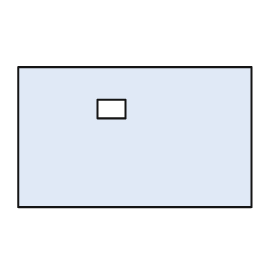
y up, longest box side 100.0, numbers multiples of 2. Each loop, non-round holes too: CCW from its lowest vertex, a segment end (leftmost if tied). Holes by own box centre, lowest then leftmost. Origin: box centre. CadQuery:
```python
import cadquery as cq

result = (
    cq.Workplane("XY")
    .moveTo(-50.0, -30.0)
    .lineTo(50.0, -30.0)
    .lineTo(50.0, 30.0)
    .lineTo(-50.0, 30.0)
    .close()
    .moveTo(-16.0, 8.0)
    .lineTo(-4.0, 8.0)
    .lineTo(-4.0, 16.0)
    .lineTo(-16.0, 16.0)
    .close()
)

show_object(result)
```